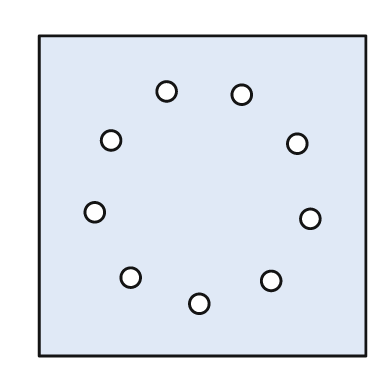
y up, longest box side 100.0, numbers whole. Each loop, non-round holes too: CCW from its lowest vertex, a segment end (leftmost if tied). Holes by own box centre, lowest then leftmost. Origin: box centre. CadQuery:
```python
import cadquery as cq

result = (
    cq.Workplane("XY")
    .moveTo(-50.0, -49.0)
    .lineTo(50.0, -49.0)
    .lineTo(50.0, 49.0)
    .lineTo(-50.0, 49.0)
    .close()
    .moveTo(-1.0, -33.0)
    .circle(3.0)
    .moveTo(21.0, -26.0)
    .circle(3.0)
    .moveTo(-22.0, -25.0)
    .circle(3.0)
    .moveTo(33.0, -7.0)
    .circle(3.0)
    .moveTo(-33.0, -5.0)
    .circle(3.0)
    .moveTo(29.0, 16.0)
    .circle(3.0)
    .moveTo(-28.0, 17.0)
    .circle(3.0)
    .moveTo(12.0, 31.0)
    .circle(3.0)
    .moveTo(-11.0, 32.0)
    .circle(3.0)
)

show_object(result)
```